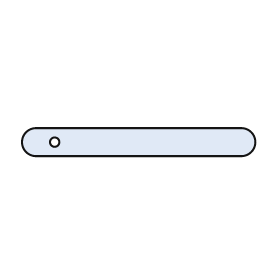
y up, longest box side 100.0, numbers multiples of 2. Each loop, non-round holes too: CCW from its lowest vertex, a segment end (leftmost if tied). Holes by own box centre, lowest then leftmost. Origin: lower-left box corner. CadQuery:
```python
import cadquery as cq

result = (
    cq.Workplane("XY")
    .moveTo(6.0, 0.0)
    .lineTo(94.0, 0.0)
    .threePointArc((100.0, 6.0), (94.0, 12.0))
    .lineTo(6.0, 12.0)
    .threePointArc((0.0, 6.0), (6.0, 0.0))
    .close()
    .moveTo(14.0, 6.0)
    .circle(2.0)
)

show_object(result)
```